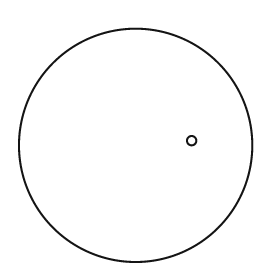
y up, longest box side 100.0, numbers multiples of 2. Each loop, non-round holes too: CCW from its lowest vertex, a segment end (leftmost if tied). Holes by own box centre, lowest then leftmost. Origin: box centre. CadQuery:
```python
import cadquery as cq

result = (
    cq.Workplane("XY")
    .moveTo(0.0, 0.0)
    .circle(50.0)
    .moveTo(24.0, 2.0)
    .circle(2.0)
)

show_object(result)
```